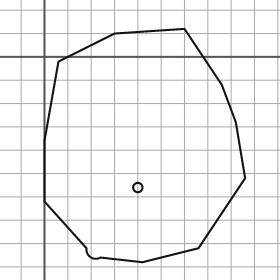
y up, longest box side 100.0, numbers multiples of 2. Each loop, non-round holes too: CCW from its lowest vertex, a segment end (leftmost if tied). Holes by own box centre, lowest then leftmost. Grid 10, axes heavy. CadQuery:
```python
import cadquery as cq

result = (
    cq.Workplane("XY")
    .moveTo(42.0, -88.0)
    .lineTo(66.0, -82.0)
    .lineTo(86.0, -52.0)
    .lineTo(82.0, -28.0)
    .lineTo(76.0, -12.0)
    .lineTo(60.0, 12.0)
    .lineTo(30.0, 10.0)
    .lineTo(6.0, -2.0)
    .lineTo(0.0, -36.0)
    .lineTo(0.0, -62.0)
    .lineTo(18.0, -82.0)
    .threePointArc((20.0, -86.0), (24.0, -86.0))
    .close()
    .moveTo(40.0, -56.0)
    .circle(2.0)
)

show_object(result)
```